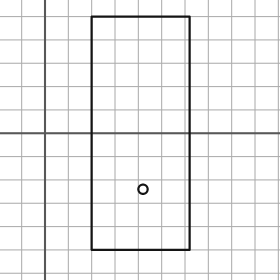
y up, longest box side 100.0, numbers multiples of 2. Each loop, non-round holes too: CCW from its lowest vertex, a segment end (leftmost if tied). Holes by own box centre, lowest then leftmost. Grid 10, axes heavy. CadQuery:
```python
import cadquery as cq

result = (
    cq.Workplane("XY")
    .moveTo(20.0, -50.0)
    .lineTo(62.0, -50.0)
    .lineTo(62.0, 50.0)
    .lineTo(20.0, 50.0)
    .close()
    .moveTo(42.0, -24.0)
    .circle(2.0)
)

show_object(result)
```